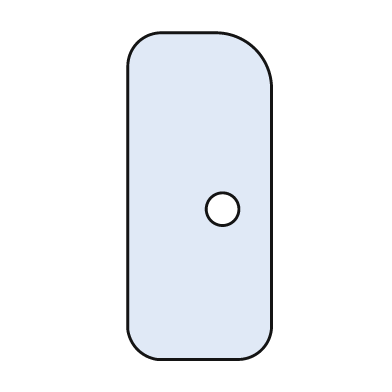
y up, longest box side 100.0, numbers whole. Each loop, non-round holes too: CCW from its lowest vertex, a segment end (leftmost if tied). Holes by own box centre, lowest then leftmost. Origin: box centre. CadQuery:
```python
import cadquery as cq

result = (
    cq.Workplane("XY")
    .moveTo(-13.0, -50.0)
    .lineTo(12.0, -50.0)
    .threePointArc((19.0, -47.0), (22.0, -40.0))
    .lineTo(22.0, 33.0)
    .threePointArc((17.0, 45.0), (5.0, 50.0))
    .lineTo(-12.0, 50.0)
    .threePointArc((-19.0, 47.0), (-22.0, 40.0))
    .lineTo(-22.0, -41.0)
    .threePointArc((-19.0, -47.0), (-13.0, -50.0))
    .close()
    .moveTo(7.0, -4.0)
    .circle(5.0)
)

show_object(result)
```